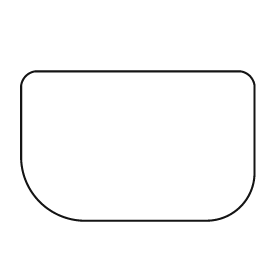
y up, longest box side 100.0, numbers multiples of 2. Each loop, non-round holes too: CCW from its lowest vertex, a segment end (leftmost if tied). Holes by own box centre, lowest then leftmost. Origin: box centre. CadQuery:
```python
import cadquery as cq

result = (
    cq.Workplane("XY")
    .moveTo(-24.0, -32.0)
    .lineTo(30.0, -32.0)
    .threePointArc((44.0, -26.0), (50.0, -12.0))
    .lineTo(50.0, 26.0)
    .threePointArc((48.0, 30.0), (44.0, 32.0))
    .lineTo(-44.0, 32.0)
    .threePointArc((-48.0, 30.0), (-50.0, 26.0))
    .lineTo(-50.0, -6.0)
    .threePointArc((-42.0, -24.0), (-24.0, -32.0))
    .close()
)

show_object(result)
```